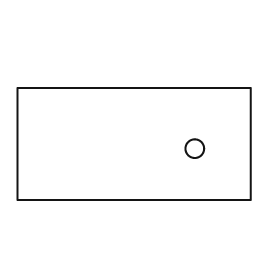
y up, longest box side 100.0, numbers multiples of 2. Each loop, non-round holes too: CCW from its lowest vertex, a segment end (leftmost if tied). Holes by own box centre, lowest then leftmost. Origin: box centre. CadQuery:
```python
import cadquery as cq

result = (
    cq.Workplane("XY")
    .moveTo(-50.0, -24.0)
    .lineTo(50.0, -24.0)
    .lineTo(50.0, 24.0)
    .lineTo(-50.0, 24.0)
    .close()
    .moveTo(26.0, -2.0)
    .circle(4.0)
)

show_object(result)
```